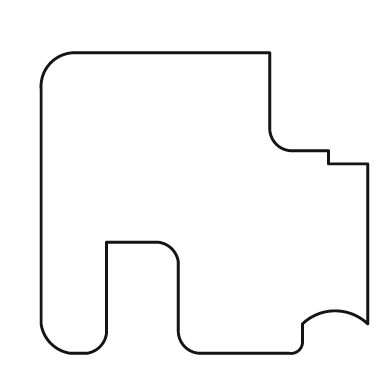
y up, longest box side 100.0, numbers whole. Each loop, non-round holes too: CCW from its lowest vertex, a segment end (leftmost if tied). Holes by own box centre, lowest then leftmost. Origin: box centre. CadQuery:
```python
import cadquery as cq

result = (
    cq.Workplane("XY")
    .moveTo(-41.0, -46.0)
    .lineTo(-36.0, -46.0)
    .threePointArc((-32.0, -44.0), (-30.0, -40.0))
    .lineTo(-30.0, -12.0)
    .lineTo(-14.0, -12.0)
    .threePointArc((-10.0, -14.0), (-8.0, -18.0))
    .lineTo(-8.0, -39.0)
    .threePointArc((-6.0, -44.0), (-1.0, -46.0))
    .lineTo(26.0, -46.0)
    .threePointArc((29.0, -45.0), (30.0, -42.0))
    .lineTo(30.0, -37.0)
    .threePointArc((40.0, -33.0), (50.0, -37.0))
    .lineTo(50.0, 12.0)
    .lineTo(38.0, 12.0)
    .lineTo(38.0, 16.0)
    .lineTo(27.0, 16.0)
    .threePointArc((22.0, 18.0), (20.0, 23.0))
    .lineTo(20.0, 46.0)
    .lineTo(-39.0, 46.0)
    .threePointArc((-47.0, 43.0), (-50.0, 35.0))
    .lineTo(-50.0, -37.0)
    .threePointArc((-47.0, -43.0), (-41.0, -46.0))
    .close()
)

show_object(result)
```